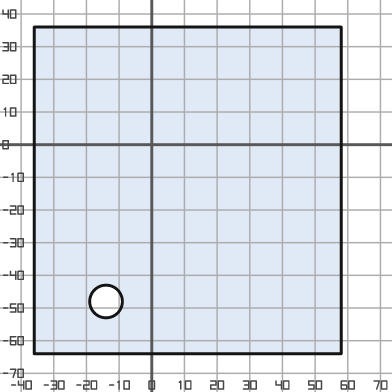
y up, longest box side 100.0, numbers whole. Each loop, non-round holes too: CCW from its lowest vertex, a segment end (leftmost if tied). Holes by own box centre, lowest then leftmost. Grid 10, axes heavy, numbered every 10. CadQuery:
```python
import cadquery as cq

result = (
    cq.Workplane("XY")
    .moveTo(-36.0, -64.0)
    .lineTo(58.0, -64.0)
    .lineTo(58.0, 36.0)
    .lineTo(-36.0, 36.0)
    .close()
    .moveTo(-14.0, -48.0)
    .circle(5.0)
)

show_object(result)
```